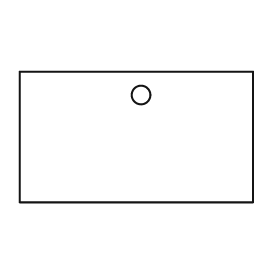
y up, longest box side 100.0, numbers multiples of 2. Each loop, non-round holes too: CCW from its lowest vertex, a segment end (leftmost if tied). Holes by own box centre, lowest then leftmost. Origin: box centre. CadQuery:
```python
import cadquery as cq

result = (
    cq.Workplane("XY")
    .moveTo(-50.0, -28.0)
    .lineTo(50.0, -28.0)
    .lineTo(50.0, 28.0)
    .lineTo(-50.0, 28.0)
    .close()
    .moveTo(2.0, 18.0)
    .circle(4.0)
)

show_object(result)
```